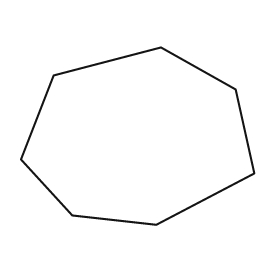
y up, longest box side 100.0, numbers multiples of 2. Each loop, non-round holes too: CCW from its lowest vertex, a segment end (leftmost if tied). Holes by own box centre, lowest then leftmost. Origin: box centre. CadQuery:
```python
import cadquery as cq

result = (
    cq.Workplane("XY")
    .moveTo(8.0, -38.0)
    .lineTo(50.0, -16.0)
    .lineTo(42.0, 20.0)
    .lineTo(10.0, 38.0)
    .lineTo(-36.0, 26.0)
    .lineTo(-50.0, -10.0)
    .lineTo(-28.0, -34.0)
    .close()
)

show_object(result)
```